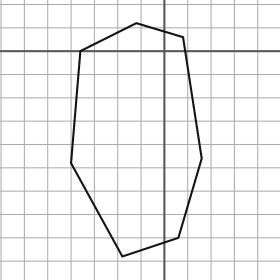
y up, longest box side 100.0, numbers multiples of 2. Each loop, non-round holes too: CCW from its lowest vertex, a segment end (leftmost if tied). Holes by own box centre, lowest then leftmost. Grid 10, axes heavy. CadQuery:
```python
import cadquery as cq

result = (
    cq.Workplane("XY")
    .moveTo(-18.0, -88.0)
    .lineTo(6.0, -80.0)
    .lineTo(16.0, -46.0)
    .lineTo(8.0, 6.0)
    .lineTo(-12.0, 12.0)
    .lineTo(-36.0, 0.0)
    .lineTo(-40.0, -48.0)
    .close()
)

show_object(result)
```